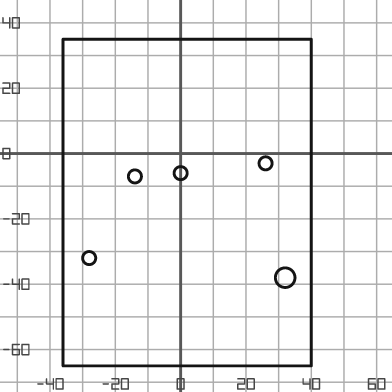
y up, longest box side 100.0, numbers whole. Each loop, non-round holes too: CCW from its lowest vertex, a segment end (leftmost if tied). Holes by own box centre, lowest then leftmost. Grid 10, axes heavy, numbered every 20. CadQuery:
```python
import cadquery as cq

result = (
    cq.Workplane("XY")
    .moveTo(-36.0, -65.0)
    .lineTo(40.0, -65.0)
    .lineTo(40.0, 35.0)
    .lineTo(-36.0, 35.0)
    .close()
    .moveTo(32.0, -38.0)
    .circle(3.0)
    .moveTo(-28.0, -32.0)
    .circle(2.0)
    .moveTo(-14.0, -7.0)
    .circle(2.0)
    .moveTo(0.0, -6.0)
    .circle(2.0)
    .moveTo(26.0, -3.0)
    .circle(2.0)
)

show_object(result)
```